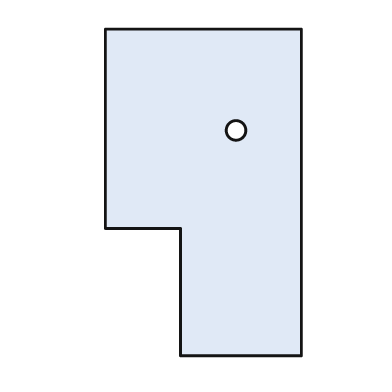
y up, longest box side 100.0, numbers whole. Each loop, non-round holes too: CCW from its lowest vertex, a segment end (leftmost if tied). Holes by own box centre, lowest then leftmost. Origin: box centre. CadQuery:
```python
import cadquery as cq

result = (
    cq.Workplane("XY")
    .moveTo(-7.0, -50.0)
    .lineTo(30.0, -50.0)
    .lineTo(30.0, 50.0)
    .lineTo(-30.0, 50.0)
    .lineTo(-30.0, -11.0)
    .lineTo(-7.0, -11.0)
    .close()
    .moveTo(10.0, 19.0)
    .circle(3.0)
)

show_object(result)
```